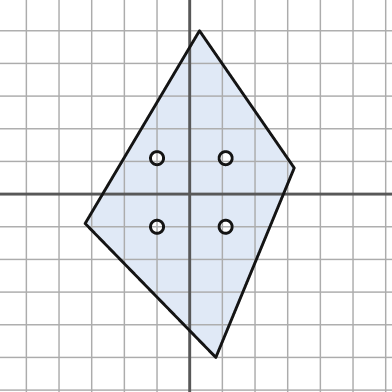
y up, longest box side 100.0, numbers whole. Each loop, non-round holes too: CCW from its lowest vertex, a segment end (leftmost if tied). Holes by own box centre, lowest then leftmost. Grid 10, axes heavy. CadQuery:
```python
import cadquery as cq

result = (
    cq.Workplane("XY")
    .moveTo(8.0, -50.0)
    .lineTo(32.0, 8.0)
    .lineTo(3.0, 50.0)
    .lineTo(-32.0, -9.0)
    .close()
    .moveTo(-10.0, -10.0)
    .circle(2.0)
    .moveTo(11.0, -10.0)
    .circle(2.0)
    .moveTo(-10.0, 11.0)
    .circle(2.0)
    .moveTo(11.0, 11.0)
    .circle(2.0)
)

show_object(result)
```